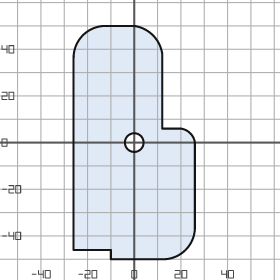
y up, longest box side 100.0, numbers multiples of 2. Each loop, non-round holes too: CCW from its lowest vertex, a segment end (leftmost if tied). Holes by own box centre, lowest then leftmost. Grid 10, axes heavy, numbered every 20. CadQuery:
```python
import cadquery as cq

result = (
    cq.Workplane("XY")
    .moveTo(-10.0, -50.0)
    .lineTo(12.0, -50.0)
    .threePointArc((22.0, -46.0), (26.0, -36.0))
    .lineTo(26.0, 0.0)
    .threePointArc((24.0, 4.0), (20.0, 6.0))
    .lineTo(12.0, 6.0)
    .lineTo(12.0, 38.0)
    .threePointArc((8.0, 46.0), (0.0, 50.0))
    .lineTo(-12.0, 50.0)
    .threePointArc((-22.0, 46.0), (-26.0, 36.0))
    .lineTo(-26.0, -46.0)
    .lineTo(-10.0, -46.0)
    .close()
    .moveTo(0.0, 0.0)
    .circle(4.0)
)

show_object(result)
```